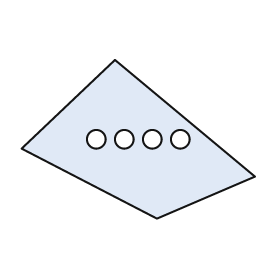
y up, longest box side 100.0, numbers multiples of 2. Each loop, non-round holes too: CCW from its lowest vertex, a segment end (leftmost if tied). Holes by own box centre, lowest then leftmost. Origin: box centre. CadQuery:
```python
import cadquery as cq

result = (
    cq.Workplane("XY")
    .moveTo(8.0, -34.0)
    .lineTo(50.0, -16.0)
    .lineTo(-10.0, 34.0)
    .lineTo(-50.0, -4.0)
    .close()
    .moveTo(-18.0, 0.0)
    .circle(4.0)
    .moveTo(-6.0, 0.0)
    .circle(4.0)
    .moveTo(6.0, 0.0)
    .circle(4.0)
    .moveTo(18.0, 0.0)
    .circle(4.0)
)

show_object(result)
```